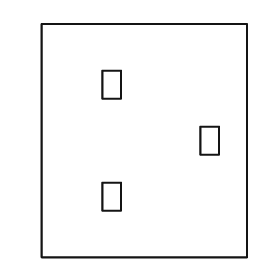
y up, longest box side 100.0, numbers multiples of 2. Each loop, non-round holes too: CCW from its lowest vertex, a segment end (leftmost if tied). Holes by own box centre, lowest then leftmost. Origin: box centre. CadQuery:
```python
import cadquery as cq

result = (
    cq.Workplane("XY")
    .moveTo(-44.0, -50.0)
    .lineTo(44.0, -50.0)
    .lineTo(44.0, 50.0)
    .lineTo(-44.0, 50.0)
    .close()
    .moveTo(-18.0, -30.0)
    .lineTo(-10.0, -30.0)
    .lineTo(-10.0, -18.0)
    .lineTo(-18.0, -18.0)
    .close()
    .moveTo(24.0, -6.0)
    .lineTo(32.0, -6.0)
    .lineTo(32.0, 6.0)
    .lineTo(24.0, 6.0)
    .close()
    .moveTo(-18.0, 18.0)
    .lineTo(-10.0, 18.0)
    .lineTo(-10.0, 30.0)
    .lineTo(-18.0, 30.0)
    .close()
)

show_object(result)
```